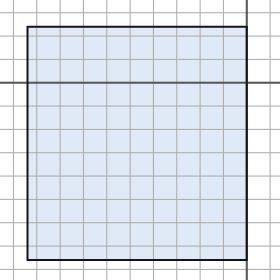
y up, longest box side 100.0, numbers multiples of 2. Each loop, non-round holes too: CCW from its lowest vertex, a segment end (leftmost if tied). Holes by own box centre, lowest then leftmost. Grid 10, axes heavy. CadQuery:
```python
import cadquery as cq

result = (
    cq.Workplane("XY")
    .moveTo(-94.0, -76.0)
    .lineTo(0.0, -76.0)
    .lineTo(0.0, 24.0)
    .lineTo(-94.0, 24.0)
    .close()
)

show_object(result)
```